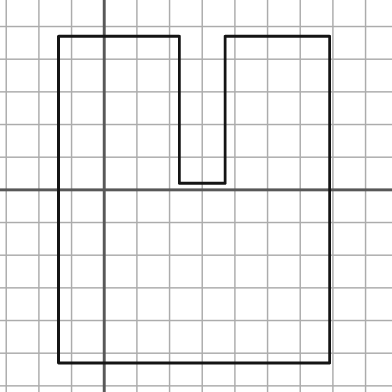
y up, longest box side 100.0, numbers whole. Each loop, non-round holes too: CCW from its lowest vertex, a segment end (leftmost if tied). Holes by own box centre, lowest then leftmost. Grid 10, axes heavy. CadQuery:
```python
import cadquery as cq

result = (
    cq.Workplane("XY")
    .moveTo(-14.0, -53.0)
    .lineTo(69.0, -53.0)
    .lineTo(69.0, 47.0)
    .lineTo(37.0, 47.0)
    .lineTo(37.0, 2.0)
    .lineTo(23.0, 2.0)
    .lineTo(23.0, 47.0)
    .lineTo(-14.0, 47.0)
    .close()
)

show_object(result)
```